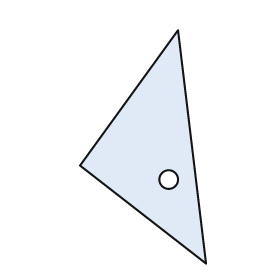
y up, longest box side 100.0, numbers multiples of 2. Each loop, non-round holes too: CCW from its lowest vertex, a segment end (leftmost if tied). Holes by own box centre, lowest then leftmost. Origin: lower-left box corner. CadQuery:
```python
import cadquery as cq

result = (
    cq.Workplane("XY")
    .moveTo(54.0, 0.0)
    .lineTo(42.0, 100.0)
    .lineTo(0.0, 42.0)
    .close()
    .moveTo(38.0, 36.0)
    .circle(4.0)
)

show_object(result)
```